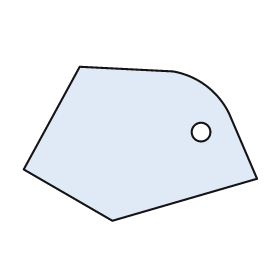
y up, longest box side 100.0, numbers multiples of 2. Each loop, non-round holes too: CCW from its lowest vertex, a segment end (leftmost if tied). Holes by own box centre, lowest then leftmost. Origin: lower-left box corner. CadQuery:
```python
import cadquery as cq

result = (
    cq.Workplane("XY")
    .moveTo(38.0, 0.0)
    .lineTo(100.0, 18.0)
    .lineTo(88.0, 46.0)
    .threePointArc((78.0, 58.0), (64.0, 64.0))
    .lineTo(24.0, 66.0)
    .lineTo(0.0, 22.0)
    .close()
    .moveTo(76.0, 38.0)
    .circle(4.0)
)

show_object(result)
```